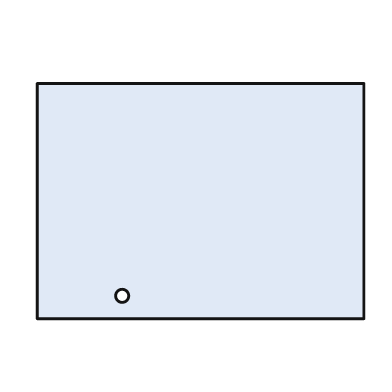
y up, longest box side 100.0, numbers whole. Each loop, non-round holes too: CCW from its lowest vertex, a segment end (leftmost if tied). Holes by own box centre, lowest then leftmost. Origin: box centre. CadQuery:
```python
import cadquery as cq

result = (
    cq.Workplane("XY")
    .moveTo(-50.0, -36.0)
    .lineTo(50.0, -36.0)
    .lineTo(50.0, 36.0)
    .lineTo(-50.0, 36.0)
    .close()
    .moveTo(-24.0, -29.0)
    .circle(2.0)
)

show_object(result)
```